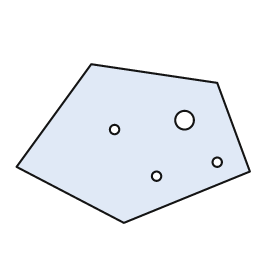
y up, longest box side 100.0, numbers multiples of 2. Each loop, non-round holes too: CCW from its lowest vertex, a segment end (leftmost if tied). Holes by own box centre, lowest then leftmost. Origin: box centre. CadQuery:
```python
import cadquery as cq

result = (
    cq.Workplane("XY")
    .moveTo(-4.0, -34.0)
    .lineTo(50.0, -12.0)
    .lineTo(36.0, 26.0)
    .lineTo(-18.0, 34.0)
    .lineTo(-50.0, -10.0)
    .close()
    .moveTo(10.0, -14.0)
    .circle(2.0)
    .moveTo(36.0, -8.0)
    .circle(2.0)
    .moveTo(-8.0, 6.0)
    .circle(2.0)
    .moveTo(22.0, 10.0)
    .circle(4.0)
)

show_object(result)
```